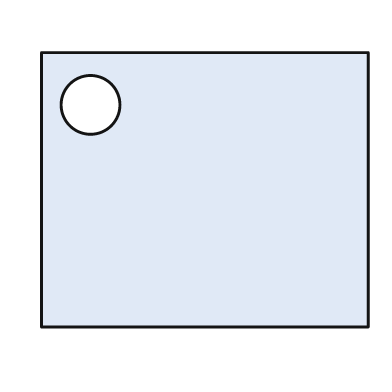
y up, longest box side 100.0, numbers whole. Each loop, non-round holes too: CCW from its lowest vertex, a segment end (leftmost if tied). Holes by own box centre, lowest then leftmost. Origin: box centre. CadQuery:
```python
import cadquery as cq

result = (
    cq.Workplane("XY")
    .moveTo(-50.0, -42.0)
    .lineTo(50.0, -42.0)
    .lineTo(50.0, 42.0)
    .lineTo(-50.0, 42.0)
    .close()
    .moveTo(-35.0, 26.0)
    .circle(9.0)
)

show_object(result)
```